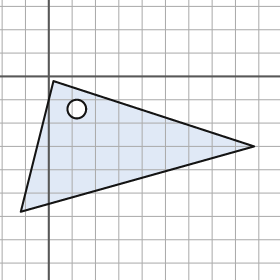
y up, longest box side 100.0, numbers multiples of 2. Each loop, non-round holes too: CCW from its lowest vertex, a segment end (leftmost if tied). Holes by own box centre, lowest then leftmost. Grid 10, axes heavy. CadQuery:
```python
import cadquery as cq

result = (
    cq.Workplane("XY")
    .moveTo(-12.0, -58.0)
    .lineTo(88.0, -30.0)
    .lineTo(2.0, -2.0)
    .close()
    .moveTo(12.0, -14.0)
    .circle(4.0)
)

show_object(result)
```